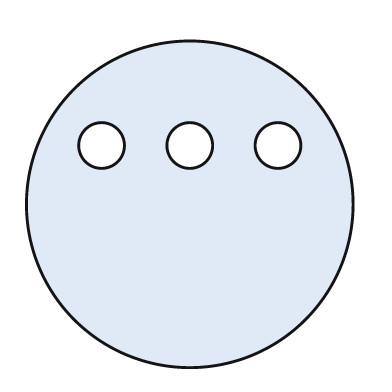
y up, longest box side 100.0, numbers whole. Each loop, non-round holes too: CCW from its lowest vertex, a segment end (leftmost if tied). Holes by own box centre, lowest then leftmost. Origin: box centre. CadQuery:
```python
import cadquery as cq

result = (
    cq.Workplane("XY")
    .moveTo(0.0, 0.0)
    .circle(50.0)
    .moveTo(-27.0, 18.0)
    .circle(7.0)
    .moveTo(0.0, 18.0)
    .circle(7.0)
    .moveTo(27.0, 18.0)
    .circle(7.0)
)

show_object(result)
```